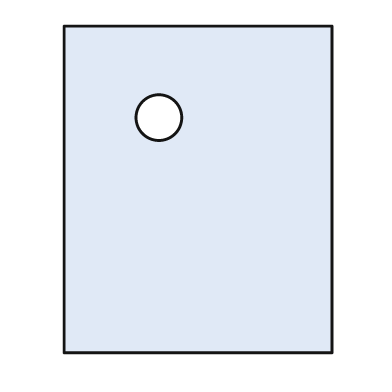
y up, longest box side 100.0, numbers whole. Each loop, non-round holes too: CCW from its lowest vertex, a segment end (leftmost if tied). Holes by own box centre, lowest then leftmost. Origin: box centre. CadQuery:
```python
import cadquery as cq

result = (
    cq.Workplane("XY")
    .moveTo(-41.0, -50.0)
    .lineTo(41.0, -50.0)
    .lineTo(41.0, 50.0)
    .lineTo(-41.0, 50.0)
    .close()
    .moveTo(-12.0, 22.0)
    .circle(7.0)
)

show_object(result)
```